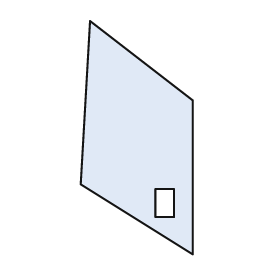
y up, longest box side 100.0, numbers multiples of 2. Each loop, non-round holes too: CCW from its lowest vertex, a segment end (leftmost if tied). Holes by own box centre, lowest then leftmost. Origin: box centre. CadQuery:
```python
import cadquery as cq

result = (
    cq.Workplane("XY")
    .moveTo(24.0, -50.0)
    .lineTo(24.0, 16.0)
    .lineTo(-20.0, 50.0)
    .lineTo(-24.0, -20.0)
    .close()
    .moveTo(8.0, -34.0)
    .lineTo(16.0, -34.0)
    .lineTo(16.0, -22.0)
    .lineTo(8.0, -22.0)
    .close()
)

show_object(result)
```